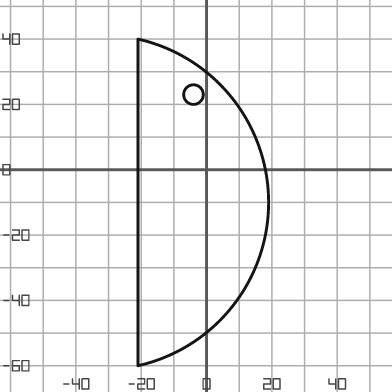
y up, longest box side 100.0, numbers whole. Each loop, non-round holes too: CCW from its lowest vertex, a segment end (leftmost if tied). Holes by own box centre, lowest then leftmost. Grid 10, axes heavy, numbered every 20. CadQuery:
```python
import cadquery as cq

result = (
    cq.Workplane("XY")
    .moveTo(-21.0, -60.0)
    .threePointArc((19.0, -10.0), (-21.0, 40.0))
    .close()
    .moveTo(-4.0, 23.0)
    .circle(3.0)
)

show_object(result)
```